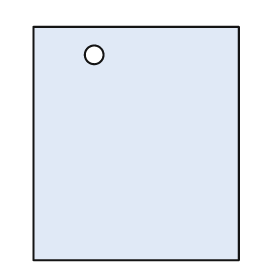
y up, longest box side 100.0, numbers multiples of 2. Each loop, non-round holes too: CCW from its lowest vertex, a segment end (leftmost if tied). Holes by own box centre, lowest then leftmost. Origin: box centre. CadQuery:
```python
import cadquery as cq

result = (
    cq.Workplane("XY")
    .moveTo(-44.0, -50.0)
    .lineTo(44.0, -50.0)
    .lineTo(44.0, 50.0)
    .lineTo(-44.0, 50.0)
    .close()
    .moveTo(-18.0, 38.0)
    .circle(4.0)
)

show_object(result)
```